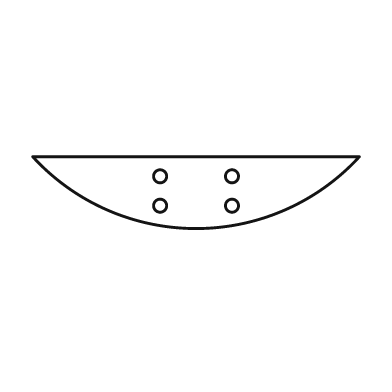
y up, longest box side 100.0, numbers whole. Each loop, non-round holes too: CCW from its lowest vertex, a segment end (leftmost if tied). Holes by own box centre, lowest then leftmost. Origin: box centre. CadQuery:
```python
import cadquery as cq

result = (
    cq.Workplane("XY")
    .moveTo(-50.0, 11.0)
    .threePointArc((0.0, -11.0), (50.0, 11.0))
    .close()
    .moveTo(-11.0, -4.0)
    .circle(2.0)
    .moveTo(11.0, -4.0)
    .circle(2.0)
    .moveTo(-11.0, 5.0)
    .circle(2.0)
    .moveTo(11.0, 5.0)
    .circle(2.0)
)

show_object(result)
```